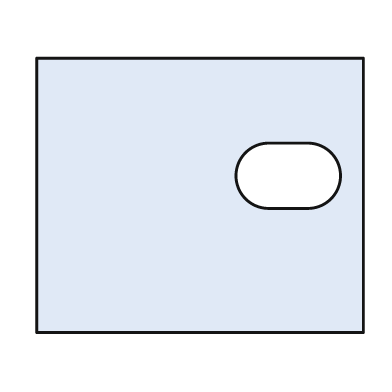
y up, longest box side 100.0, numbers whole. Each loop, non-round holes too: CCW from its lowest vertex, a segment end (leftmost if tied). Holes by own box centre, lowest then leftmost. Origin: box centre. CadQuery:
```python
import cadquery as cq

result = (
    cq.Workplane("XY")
    .moveTo(-50.0, -42.0)
    .lineTo(50.0, -42.0)
    .lineTo(50.0, 42.0)
    .lineTo(-50.0, 42.0)
    .close()
    .moveTo(21.0, -4.0)
    .lineTo(33.0, -4.0)
    .threePointArc((43.0, 6.0), (33.0, 16.0))
    .lineTo(21.0, 16.0)
    .threePointArc((11.0, 6.0), (21.0, -4.0))
    .close()
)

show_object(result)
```